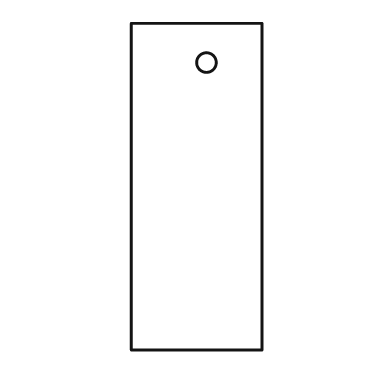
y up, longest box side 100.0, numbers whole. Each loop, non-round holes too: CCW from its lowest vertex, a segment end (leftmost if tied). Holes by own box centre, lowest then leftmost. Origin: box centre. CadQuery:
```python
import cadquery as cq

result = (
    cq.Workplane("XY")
    .moveTo(-20.0, -50.0)
    .lineTo(20.0, -50.0)
    .lineTo(20.0, 50.0)
    .lineTo(-20.0, 50.0)
    .close()
    .moveTo(3.0, 38.0)
    .circle(3.0)
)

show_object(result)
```